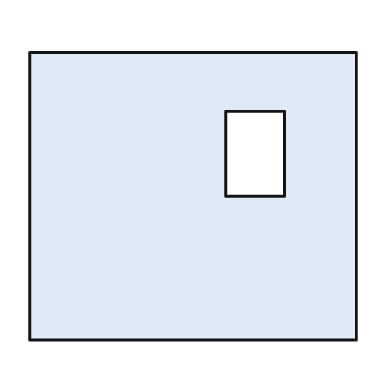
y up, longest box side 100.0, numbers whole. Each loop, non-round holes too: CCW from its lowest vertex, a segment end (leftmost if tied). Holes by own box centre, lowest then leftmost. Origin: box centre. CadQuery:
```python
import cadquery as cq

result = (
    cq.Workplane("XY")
    .moveTo(-50.0, -44.0)
    .lineTo(50.0, -44.0)
    .lineTo(50.0, 44.0)
    .lineTo(-50.0, 44.0)
    .close()
    .moveTo(10.0, 0.0)
    .lineTo(28.0, 0.0)
    .lineTo(28.0, 26.0)
    .lineTo(10.0, 26.0)
    .close()
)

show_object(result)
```